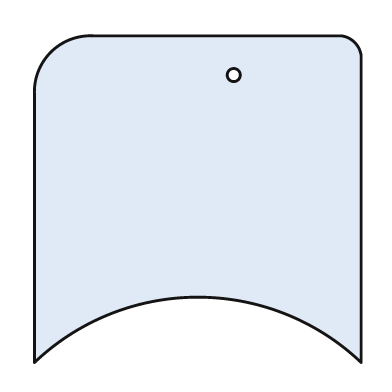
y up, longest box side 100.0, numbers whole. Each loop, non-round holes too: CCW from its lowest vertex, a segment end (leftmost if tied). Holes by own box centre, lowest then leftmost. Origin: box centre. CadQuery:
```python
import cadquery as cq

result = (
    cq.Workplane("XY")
    .moveTo(-50.0, -50.0)
    .threePointArc((0.0, -30.0), (50.0, -50.0))
    .lineTo(50.0, 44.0)
    .threePointArc((48.0, 48.0), (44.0, 50.0))
    .lineTo(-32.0, 50.0)
    .threePointArc((-45.0, 45.0), (-50.0, 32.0))
    .close()
    .moveTo(11.0, 38.0)
    .circle(2.0)
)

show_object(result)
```